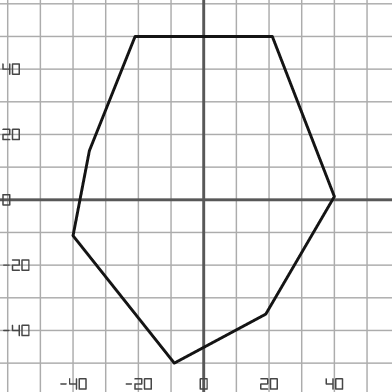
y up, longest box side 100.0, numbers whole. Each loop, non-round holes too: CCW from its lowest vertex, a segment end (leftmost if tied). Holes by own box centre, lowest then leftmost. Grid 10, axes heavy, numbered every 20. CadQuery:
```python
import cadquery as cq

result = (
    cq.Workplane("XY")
    .moveTo(-9.0, -50.0)
    .lineTo(19.0, -35.0)
    .lineTo(40.0, 1.0)
    .lineTo(21.0, 50.0)
    .lineTo(-21.0, 50.0)
    .lineTo(-35.0, 15.0)
    .lineTo(-40.0, -11.0)
    .close()
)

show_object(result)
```